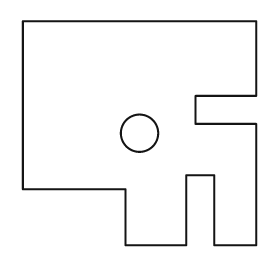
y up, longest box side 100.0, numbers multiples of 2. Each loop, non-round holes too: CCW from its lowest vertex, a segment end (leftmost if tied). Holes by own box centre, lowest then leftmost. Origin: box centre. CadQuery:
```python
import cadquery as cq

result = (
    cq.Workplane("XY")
    .moveTo(-6.0, -48.0)
    .lineTo(20.0, -48.0)
    .lineTo(20.0, -18.0)
    .lineTo(32.0, -18.0)
    .lineTo(32.0, -48.0)
    .lineTo(50.0, -48.0)
    .lineTo(50.0, 4.0)
    .lineTo(24.0, 4.0)
    .lineTo(24.0, 16.0)
    .lineTo(50.0, 16.0)
    .lineTo(50.0, 48.0)
    .lineTo(-50.0, 48.0)
    .lineTo(-50.0, -24.0)
    .lineTo(-6.0, -24.0)
    .close()
    .moveTo(0.0, 0.0)
    .circle(8.0)
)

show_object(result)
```